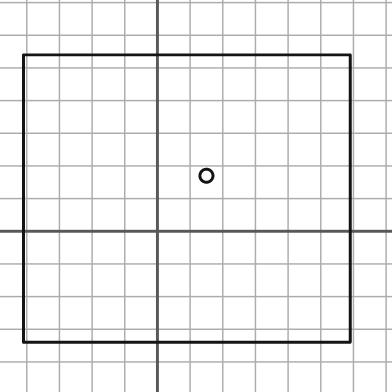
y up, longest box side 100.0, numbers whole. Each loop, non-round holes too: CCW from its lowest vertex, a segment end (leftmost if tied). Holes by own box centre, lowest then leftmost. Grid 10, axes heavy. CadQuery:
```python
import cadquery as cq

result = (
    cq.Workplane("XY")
    .moveTo(-41.0, -34.0)
    .lineTo(59.0, -34.0)
    .lineTo(59.0, 54.0)
    .lineTo(-41.0, 54.0)
    .close()
    .moveTo(15.0, 17.0)
    .circle(2.0)
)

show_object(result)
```